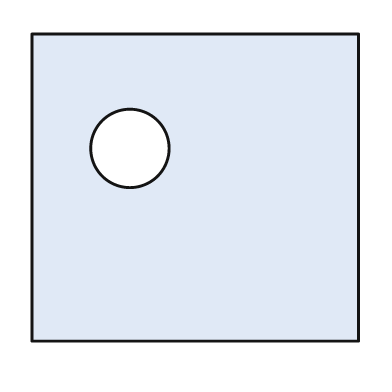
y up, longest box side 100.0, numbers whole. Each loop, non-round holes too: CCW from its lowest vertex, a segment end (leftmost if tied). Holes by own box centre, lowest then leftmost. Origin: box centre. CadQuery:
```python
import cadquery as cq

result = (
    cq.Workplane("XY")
    .moveTo(-50.0, -47.0)
    .lineTo(50.0, -47.0)
    .lineTo(50.0, 47.0)
    .lineTo(-50.0, 47.0)
    .close()
    .moveTo(-20.0, 12.0)
    .circle(12.0)
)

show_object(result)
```